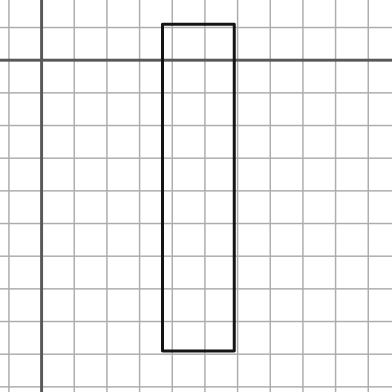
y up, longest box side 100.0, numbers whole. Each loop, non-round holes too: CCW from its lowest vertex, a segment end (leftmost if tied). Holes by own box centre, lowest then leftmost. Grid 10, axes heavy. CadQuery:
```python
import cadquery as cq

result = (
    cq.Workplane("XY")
    .moveTo(37.0, -89.0)
    .lineTo(59.0, -89.0)
    .lineTo(59.0, 11.0)
    .lineTo(37.0, 11.0)
    .close()
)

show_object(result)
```